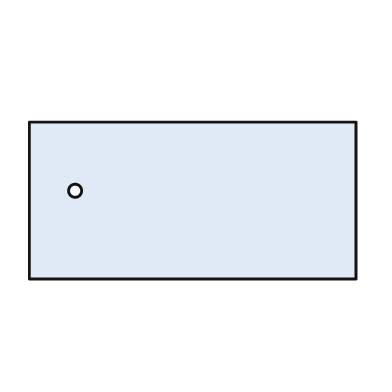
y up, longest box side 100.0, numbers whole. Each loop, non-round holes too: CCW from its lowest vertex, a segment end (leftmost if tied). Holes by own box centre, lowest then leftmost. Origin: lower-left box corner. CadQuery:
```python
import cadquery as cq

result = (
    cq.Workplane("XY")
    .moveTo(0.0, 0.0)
    .lineTo(100.0, 0.0)
    .lineTo(100.0, 48.0)
    .lineTo(0.0, 48.0)
    .close()
    .moveTo(14.0, 27.0)
    .circle(2.0)
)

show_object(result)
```